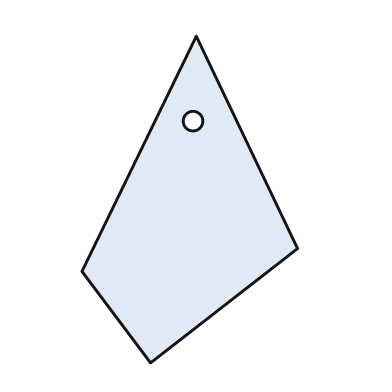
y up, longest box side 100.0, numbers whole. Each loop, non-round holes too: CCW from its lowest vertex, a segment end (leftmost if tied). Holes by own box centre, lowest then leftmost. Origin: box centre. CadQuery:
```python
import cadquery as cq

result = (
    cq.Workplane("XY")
    .moveTo(-12.0, -50.0)
    .lineTo(33.0, -15.0)
    .lineTo(2.0, 50.0)
    .lineTo(-33.0, -22.0)
    .close()
    .moveTo(1.0, 24.0)
    .circle(3.0)
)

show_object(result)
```